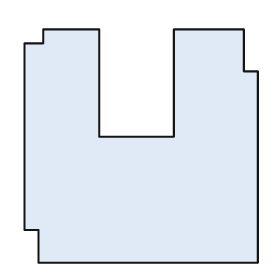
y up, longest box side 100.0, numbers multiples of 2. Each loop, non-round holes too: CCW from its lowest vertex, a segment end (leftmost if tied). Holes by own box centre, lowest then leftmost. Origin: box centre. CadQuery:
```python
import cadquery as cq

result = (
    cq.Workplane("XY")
    .moveTo(-44.0, -50.0)
    .lineTo(50.0, -50.0)
    .lineTo(50.0, 32.0)
    .lineTo(44.0, 32.0)
    .lineTo(44.0, 50.0)
    .lineTo(14.0, 50.0)
    .lineTo(14.0, 4.0)
    .lineTo(-18.0, 4.0)
    .lineTo(-18.0, 50.0)
    .lineTo(-42.0, 50.0)
    .lineTo(-42.0, 44.0)
    .lineTo(-50.0, 44.0)
    .lineTo(-50.0, -36.0)
    .lineTo(-44.0, -36.0)
    .close()
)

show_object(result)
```